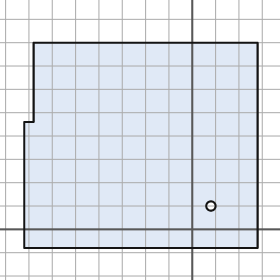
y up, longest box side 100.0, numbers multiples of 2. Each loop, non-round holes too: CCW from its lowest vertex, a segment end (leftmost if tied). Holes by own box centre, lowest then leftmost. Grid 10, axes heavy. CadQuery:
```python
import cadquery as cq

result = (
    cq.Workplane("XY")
    .moveTo(-72.0, -8.0)
    .lineTo(28.0, -8.0)
    .lineTo(28.0, 80.0)
    .lineTo(-68.0, 80.0)
    .lineTo(-68.0, 46.0)
    .lineTo(-72.0, 46.0)
    .close()
    .moveTo(8.0, 10.0)
    .circle(2.0)
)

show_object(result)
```